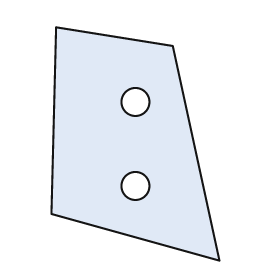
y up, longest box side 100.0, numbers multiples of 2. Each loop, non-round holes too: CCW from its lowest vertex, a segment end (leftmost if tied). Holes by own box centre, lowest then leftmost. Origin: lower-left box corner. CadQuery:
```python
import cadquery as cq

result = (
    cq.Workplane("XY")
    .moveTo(72.0, 0.0)
    .lineTo(52.0, 92.0)
    .lineTo(2.0, 100.0)
    .lineTo(0.0, 20.0)
    .close()
    .moveTo(36.0, 32.0)
    .circle(6.0)
    .moveTo(36.0, 68.0)
    .circle(6.0)
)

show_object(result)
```